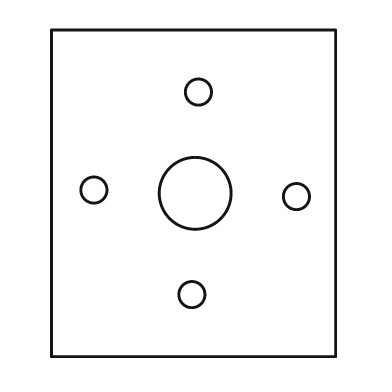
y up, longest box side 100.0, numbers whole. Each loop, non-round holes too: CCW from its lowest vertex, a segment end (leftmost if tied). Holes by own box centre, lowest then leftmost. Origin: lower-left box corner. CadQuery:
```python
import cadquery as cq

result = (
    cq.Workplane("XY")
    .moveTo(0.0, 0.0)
    .lineTo(87.0, 0.0)
    .lineTo(87.0, 100.0)
    .lineTo(0.0, 100.0)
    .close()
    .moveTo(43.0, 19.0)
    .circle(4.0)
    .moveTo(75.0, 49.0)
    .circle(4.0)
    .moveTo(44.0, 50.0)
    .circle(11.0)
    .moveTo(13.0, 51.0)
    .circle(4.0)
    .moveTo(45.0, 81.0)
    .circle(4.0)
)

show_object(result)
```